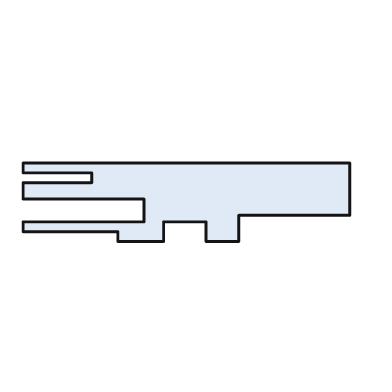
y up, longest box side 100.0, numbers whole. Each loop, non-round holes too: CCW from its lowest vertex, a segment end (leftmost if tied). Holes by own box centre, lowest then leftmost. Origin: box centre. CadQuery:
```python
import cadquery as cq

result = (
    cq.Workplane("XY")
    .moveTo(-21.0, -12.0)
    .lineTo(-7.0, -12.0)
    .lineTo(-7.0, -6.0)
    .lineTo(6.0, -6.0)
    .lineTo(6.0, -12.0)
    .lineTo(16.0, -12.0)
    .lineTo(16.0, -4.0)
    .lineTo(50.0, -4.0)
    .lineTo(50.0, 12.0)
    .lineTo(-50.0, 12.0)
    .lineTo(-50.0, 9.0)
    .lineTo(-29.0, 9.0)
    .lineTo(-29.0, 6.0)
    .lineTo(-50.0, 6.0)
    .lineTo(-50.0, 1.0)
    .lineTo(-13.0, 1.0)
    .lineTo(-13.0, -6.0)
    .lineTo(-50.0, -6.0)
    .lineTo(-50.0, -9.0)
    .lineTo(-21.0, -9.0)
    .close()
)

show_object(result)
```